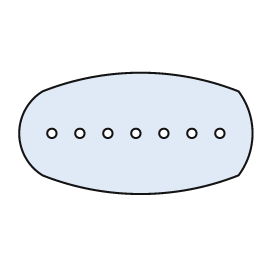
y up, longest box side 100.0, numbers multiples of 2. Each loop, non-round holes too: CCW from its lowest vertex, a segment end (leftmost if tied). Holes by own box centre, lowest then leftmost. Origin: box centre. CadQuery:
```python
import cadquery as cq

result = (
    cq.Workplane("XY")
    .moveTo(-40.0, -18.0)
    .threePointArc((2.0, -26.0), (44.0, -18.0))
    .threePointArc((50.0, 0.0), (44.0, 18.0))
    .threePointArc((2.0, 26.0), (-40.0, 18.0))
    .threePointArc((-50.0, 0.0), (-40.0, -18.0))
    .close()
    .moveTo(-36.0, 0.0)
    .circle(2.0)
    .moveTo(-24.0, 0.0)
    .circle(2.0)
    .moveTo(-12.0, 0.0)
    .circle(2.0)
    .moveTo(0.0, 0.0)
    .circle(2.0)
    .moveTo(12.0, 0.0)
    .circle(2.0)
    .moveTo(24.0, 0.0)
    .circle(2.0)
    .moveTo(36.0, 0.0)
    .circle(2.0)
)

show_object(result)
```